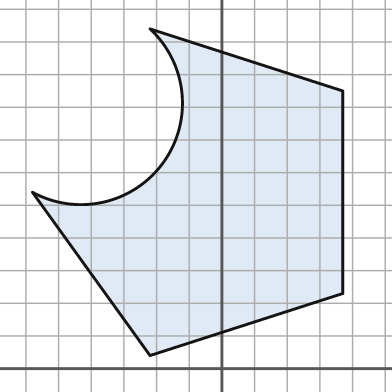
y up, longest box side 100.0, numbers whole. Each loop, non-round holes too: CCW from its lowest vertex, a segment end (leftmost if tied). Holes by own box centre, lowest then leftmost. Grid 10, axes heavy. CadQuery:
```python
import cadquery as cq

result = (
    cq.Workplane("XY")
    .moveTo(-22.0, 4.0)
    .lineTo(37.0, 23.0)
    .lineTo(37.0, 85.0)
    .lineTo(-22.0, 104.0)
    .threePointArc((-18.0, 63.0), (-58.0, 54.0))
    .close()
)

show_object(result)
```